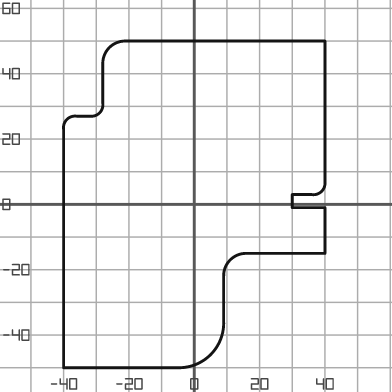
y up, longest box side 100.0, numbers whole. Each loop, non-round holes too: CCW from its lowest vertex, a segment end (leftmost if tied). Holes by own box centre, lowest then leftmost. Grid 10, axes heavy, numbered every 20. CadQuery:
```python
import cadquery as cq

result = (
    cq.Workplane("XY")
    .moveTo(-40.0, -50.0)
    .lineTo(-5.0, -50.0)
    .threePointArc((5.0, -46.0), (9.0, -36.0))
    .lineTo(9.0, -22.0)
    .threePointArc((11.0, -17.0), (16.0, -15.0))
    .lineTo(40.0, -15.0)
    .lineTo(40.0, -1.0)
    .lineTo(30.0, -1.0)
    .lineTo(30.0, 3.0)
    .lineTo(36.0, 3.0)
    .threePointArc((39.0, 4.0), (40.0, 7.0))
    .lineTo(40.0, 50.0)
    .lineTo(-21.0, 50.0)
    .threePointArc((-26.0, 48.0), (-28.0, 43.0))
    .lineTo(-28.0, 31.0)
    .threePointArc((-29.0, 28.0), (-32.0, 27.0))
    .lineTo(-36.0, 27.0)
    .threePointArc((-39.0, 26.0), (-40.0, 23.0))
    .close()
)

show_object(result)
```